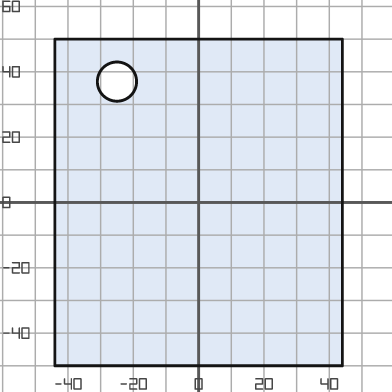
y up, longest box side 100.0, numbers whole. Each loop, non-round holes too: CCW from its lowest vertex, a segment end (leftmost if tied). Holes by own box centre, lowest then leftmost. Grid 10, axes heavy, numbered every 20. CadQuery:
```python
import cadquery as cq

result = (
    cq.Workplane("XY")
    .moveTo(-44.0, -50.0)
    .lineTo(44.0, -50.0)
    .lineTo(44.0, 50.0)
    .lineTo(-44.0, 50.0)
    .close()
    .moveTo(-25.0, 37.0)
    .circle(6.0)
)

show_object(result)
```